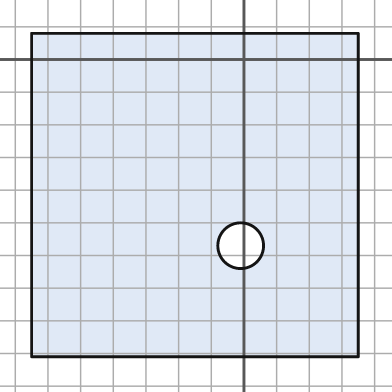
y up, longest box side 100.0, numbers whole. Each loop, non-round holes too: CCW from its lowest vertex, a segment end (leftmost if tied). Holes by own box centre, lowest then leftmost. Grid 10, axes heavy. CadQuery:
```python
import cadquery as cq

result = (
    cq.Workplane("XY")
    .moveTo(-65.0, -91.0)
    .lineTo(35.0, -91.0)
    .lineTo(35.0, 8.0)
    .lineTo(-65.0, 8.0)
    .close()
    .moveTo(-1.0, -57.0)
    .circle(7.0)
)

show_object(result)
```